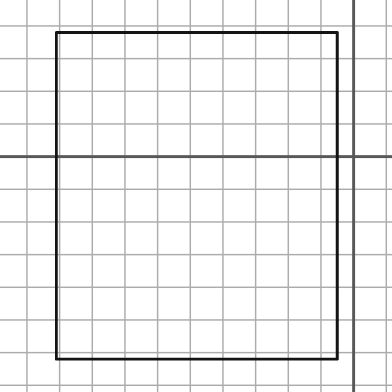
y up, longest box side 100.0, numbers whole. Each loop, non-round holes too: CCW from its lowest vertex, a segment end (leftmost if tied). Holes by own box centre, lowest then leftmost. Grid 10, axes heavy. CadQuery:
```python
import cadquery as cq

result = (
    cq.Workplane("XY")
    .moveTo(-91.0, -62.0)
    .lineTo(-5.0, -62.0)
    .lineTo(-5.0, 38.0)
    .lineTo(-91.0, 38.0)
    .close()
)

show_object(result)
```